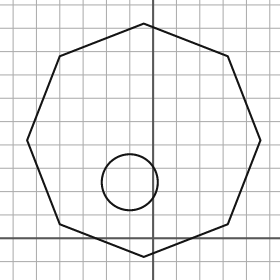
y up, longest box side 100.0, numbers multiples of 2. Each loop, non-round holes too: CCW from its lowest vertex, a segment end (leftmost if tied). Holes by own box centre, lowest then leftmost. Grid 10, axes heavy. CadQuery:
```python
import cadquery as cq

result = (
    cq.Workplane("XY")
    .moveTo(-4.0, -8.0)
    .lineTo(32.0, 6.0)
    .lineTo(46.0, 42.0)
    .lineTo(32.0, 78.0)
    .lineTo(-4.0, 92.0)
    .lineTo(-40.0, 78.0)
    .lineTo(-54.0, 42.0)
    .lineTo(-40.0, 6.0)
    .close()
    .moveTo(-10.0, 24.0)
    .circle(12.0)
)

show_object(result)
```